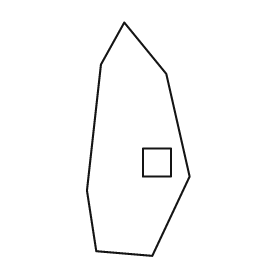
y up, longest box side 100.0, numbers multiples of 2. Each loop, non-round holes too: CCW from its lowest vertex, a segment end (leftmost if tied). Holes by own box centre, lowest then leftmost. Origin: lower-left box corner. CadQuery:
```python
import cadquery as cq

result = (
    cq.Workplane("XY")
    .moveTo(28.0, 0.0)
    .lineTo(44.0, 34.0)
    .lineTo(34.0, 78.0)
    .lineTo(16.0, 100.0)
    .lineTo(6.0, 82.0)
    .lineTo(0.0, 28.0)
    .lineTo(4.0, 2.0)
    .close()
    .moveTo(24.0, 34.0)
    .lineTo(36.0, 34.0)
    .lineTo(36.0, 46.0)
    .lineTo(24.0, 46.0)
    .close()
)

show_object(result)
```